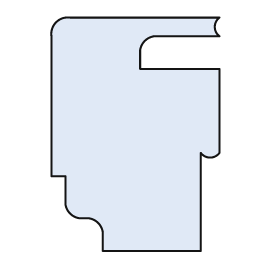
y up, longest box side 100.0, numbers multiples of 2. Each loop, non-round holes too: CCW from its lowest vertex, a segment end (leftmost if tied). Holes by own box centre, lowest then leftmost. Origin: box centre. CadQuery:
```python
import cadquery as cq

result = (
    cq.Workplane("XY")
    .moveTo(-14.0, -50.0)
    .lineTo(28.0, -50.0)
    .lineTo(28.0, -8.0)
    .threePointArc((32.0, -10.0), (36.0, -8.0))
    .lineTo(36.0, 28.0)
    .lineTo(2.0, 28.0)
    .lineTo(2.0, 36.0)
    .threePointArc((4.0, 40.0), (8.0, 42.0))
    .lineTo(36.0, 42.0)
    .threePointArc((34.0, 46.0), (36.0, 50.0))
    .lineTo(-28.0, 50.0)
    .threePointArc((-34.0, 48.0), (-36.0, 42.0))
    .lineTo(-36.0, -18.0)
    .lineTo(-30.0, -18.0)
    .lineTo(-30.0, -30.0)
    .threePointArc((-28.0, -34.0), (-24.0, -36.0))
    .lineTo(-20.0, -36.0)
    .threePointArc((-16.0, -38.0), (-14.0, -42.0))
    .close()
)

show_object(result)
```